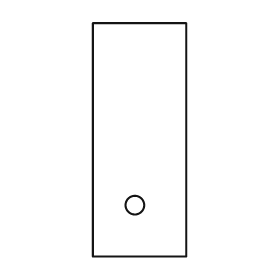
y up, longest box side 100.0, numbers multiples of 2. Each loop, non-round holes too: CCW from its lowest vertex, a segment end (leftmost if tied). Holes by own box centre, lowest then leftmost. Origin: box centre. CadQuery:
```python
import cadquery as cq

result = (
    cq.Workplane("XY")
    .moveTo(-20.0, -50.0)
    .lineTo(20.0, -50.0)
    .lineTo(20.0, 50.0)
    .lineTo(-20.0, 50.0)
    .close()
    .moveTo(-2.0, -28.0)
    .circle(4.0)
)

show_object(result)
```